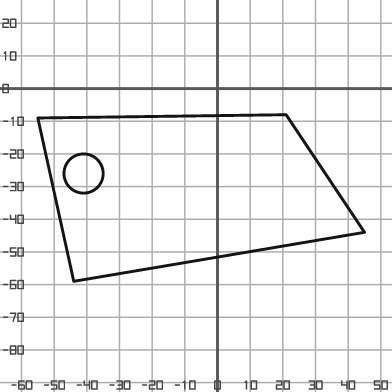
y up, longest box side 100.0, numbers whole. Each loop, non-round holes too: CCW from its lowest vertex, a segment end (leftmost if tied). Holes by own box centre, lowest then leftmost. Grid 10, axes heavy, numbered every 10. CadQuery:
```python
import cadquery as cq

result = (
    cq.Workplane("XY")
    .moveTo(-44.0, -59.0)
    .lineTo(45.0, -44.0)
    .lineTo(21.0, -8.0)
    .lineTo(-55.0, -9.0)
    .close()
    .moveTo(-41.0, -26.0)
    .circle(6.0)
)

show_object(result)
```